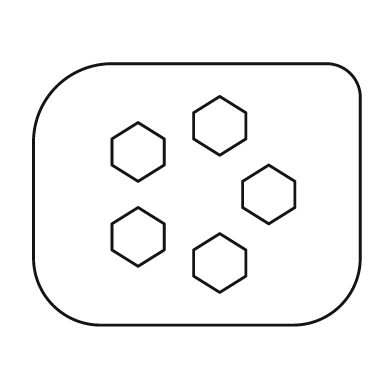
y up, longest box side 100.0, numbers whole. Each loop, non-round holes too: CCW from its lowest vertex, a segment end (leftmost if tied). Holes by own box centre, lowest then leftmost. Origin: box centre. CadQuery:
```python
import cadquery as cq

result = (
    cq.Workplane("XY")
    .moveTo(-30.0, -40.0)
    .lineTo(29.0, -40.0)
    .threePointArc((44.0, -34.0), (50.0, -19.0))
    .lineTo(50.0, 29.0)
    .threePointArc((47.0, 37.0), (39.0, 40.0))
    .lineTo(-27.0, 40.0)
    .threePointArc((-43.0, 33.0), (-50.0, 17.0))
    .lineTo(-50.0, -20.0)
    .threePointArc((-44.0, -34.0), (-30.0, -40.0))
    .close()
    .moveTo(7.0, -30.0)
    .lineTo(15.0, -25.0)
    .lineTo(15.0, -17.0)
    .lineTo(7.0, -12.0)
    .lineTo(-1.0, -17.0)
    .lineTo(-1.0, -25.0)
    .close()
    .moveTo(-18.0, -22.0)
    .lineTo(-10.0, -17.0)
    .lineTo(-10.0, -9.0)
    .lineTo(-18.0, -4.0)
    .lineTo(-26.0, -9.0)
    .lineTo(-26.0, -17.0)
    .close()
    .moveTo(22.0, -9.0)
    .lineTo(30.0, -4.0)
    .lineTo(30.0, 4.0)
    .lineTo(22.0, 9.0)
    .lineTo(14.0, 4.0)
    .lineTo(14.0, -4.0)
    .close()
    .moveTo(-18.0, 4.0)
    .lineTo(-10.0, 9.0)
    .lineTo(-10.0, 17.0)
    .lineTo(-18.0, 22.0)
    .lineTo(-26.0, 17.0)
    .lineTo(-26.0, 9.0)
    .close()
    .moveTo(7.0, 12.0)
    .lineTo(15.0, 17.0)
    .lineTo(15.0, 25.0)
    .lineTo(7.0, 30.0)
    .lineTo(-1.0, 25.0)
    .lineTo(-1.0, 17.0)
    .close()
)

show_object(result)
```